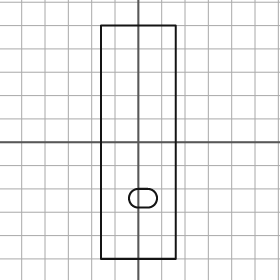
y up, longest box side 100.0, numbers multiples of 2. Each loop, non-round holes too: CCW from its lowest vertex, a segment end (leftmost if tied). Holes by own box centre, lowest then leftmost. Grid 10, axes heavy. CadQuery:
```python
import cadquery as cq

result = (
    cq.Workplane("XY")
    .moveTo(-16.0, -50.0)
    .lineTo(16.0, -50.0)
    .lineTo(16.0, 50.0)
    .lineTo(-16.0, 50.0)
    .close()
    .moveTo(0.0, -28.0)
    .lineTo(4.0, -28.0)
    .threePointArc((8.0, -24.0), (4.0, -20.0))
    .lineTo(0.0, -20.0)
    .threePointArc((-4.0, -24.0), (0.0, -28.0))
    .close()
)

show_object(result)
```